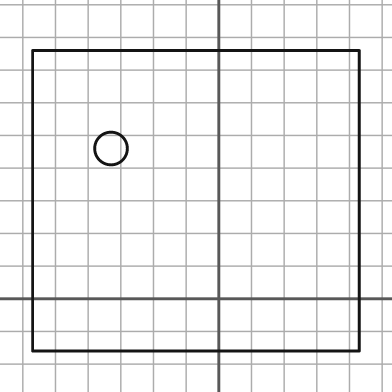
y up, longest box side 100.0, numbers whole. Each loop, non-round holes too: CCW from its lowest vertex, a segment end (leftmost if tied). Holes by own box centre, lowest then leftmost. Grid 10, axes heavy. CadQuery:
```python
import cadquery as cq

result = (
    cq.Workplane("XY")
    .moveTo(-57.0, -16.0)
    .lineTo(43.0, -16.0)
    .lineTo(43.0, 76.0)
    .lineTo(-57.0, 76.0)
    .close()
    .moveTo(-33.0, 46.0)
    .circle(5.0)
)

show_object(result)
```